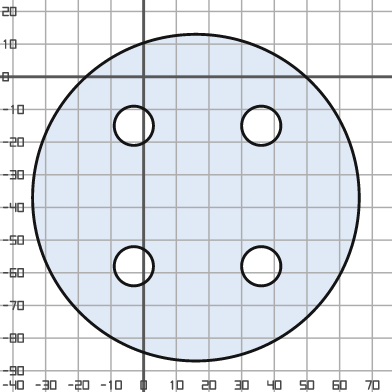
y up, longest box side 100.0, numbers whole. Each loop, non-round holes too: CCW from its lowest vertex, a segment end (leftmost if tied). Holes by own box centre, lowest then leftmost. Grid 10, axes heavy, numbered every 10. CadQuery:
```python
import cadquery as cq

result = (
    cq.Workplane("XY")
    .moveTo(16.0, -37.0)
    .circle(50.0)
    .moveTo(-3.0, -58.0)
    .circle(6.0)
    .moveTo(36.0, -58.0)
    .circle(6.0)
    .moveTo(-3.0, -15.0)
    .circle(6.0)
    .moveTo(36.0, -15.0)
    .circle(6.0)
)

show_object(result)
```